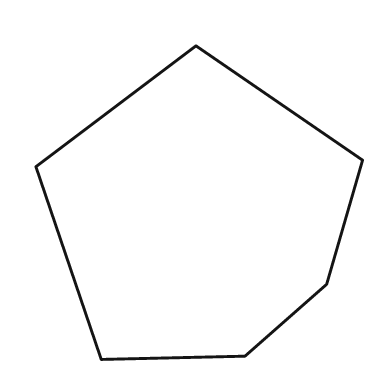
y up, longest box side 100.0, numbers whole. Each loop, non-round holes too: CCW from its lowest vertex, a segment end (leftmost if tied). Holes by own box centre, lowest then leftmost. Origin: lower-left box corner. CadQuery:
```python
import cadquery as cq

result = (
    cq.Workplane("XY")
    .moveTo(20.0, 0.0)
    .lineTo(64.0, 1.0)
    .lineTo(89.0, 23.0)
    .lineTo(100.0, 61.0)
    .lineTo(49.0, 96.0)
    .lineTo(0.0, 59.0)
    .close()
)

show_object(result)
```